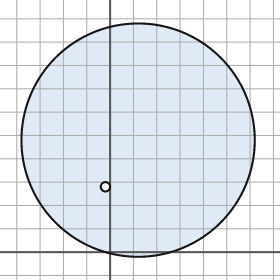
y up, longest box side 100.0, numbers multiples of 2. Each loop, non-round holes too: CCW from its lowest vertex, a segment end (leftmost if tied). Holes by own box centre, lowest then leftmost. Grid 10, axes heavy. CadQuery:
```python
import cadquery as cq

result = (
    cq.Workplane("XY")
    .moveTo(12.0, 48.0)
    .circle(50.0)
    .moveTo(-2.0, 28.0)
    .circle(2.0)
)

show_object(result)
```